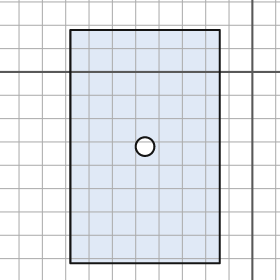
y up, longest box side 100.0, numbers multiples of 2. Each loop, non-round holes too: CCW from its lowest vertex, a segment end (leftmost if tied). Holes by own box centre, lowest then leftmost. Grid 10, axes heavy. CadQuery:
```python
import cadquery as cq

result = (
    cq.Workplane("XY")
    .moveTo(-78.0, -82.0)
    .lineTo(-14.0, -82.0)
    .lineTo(-14.0, 18.0)
    .lineTo(-78.0, 18.0)
    .close()
    .moveTo(-46.0, -32.0)
    .circle(4.0)
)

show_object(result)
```